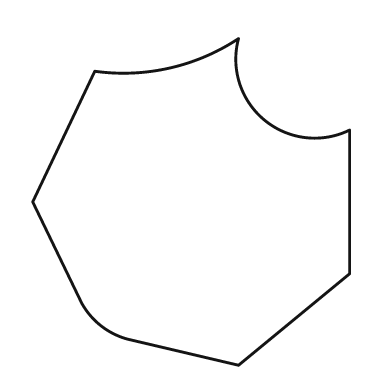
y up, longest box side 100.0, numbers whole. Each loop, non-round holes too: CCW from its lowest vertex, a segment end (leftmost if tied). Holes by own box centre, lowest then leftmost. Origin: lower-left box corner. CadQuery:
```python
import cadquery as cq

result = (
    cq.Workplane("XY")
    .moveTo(63.0, 0.0)
    .lineTo(97.0, 28.0)
    .lineTo(97.0, 72.0)
    .threePointArc((71.0, 75.0), (63.0, 100.0))
    .threePointArc((42.0, 91.0), (19.0, 90.0))
    .lineTo(0.0, 50.0)
    .lineTo(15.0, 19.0)
    .threePointArc((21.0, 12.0), (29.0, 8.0))
    .close()
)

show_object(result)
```